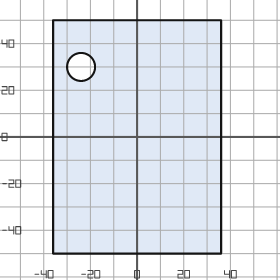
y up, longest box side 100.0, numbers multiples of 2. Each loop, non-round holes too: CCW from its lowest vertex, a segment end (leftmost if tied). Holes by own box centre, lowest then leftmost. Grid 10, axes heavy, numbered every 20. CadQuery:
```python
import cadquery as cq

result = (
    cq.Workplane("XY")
    .moveTo(-36.0, -50.0)
    .lineTo(36.0, -50.0)
    .lineTo(36.0, 50.0)
    .lineTo(-36.0, 50.0)
    .close()
    .moveTo(-24.0, 30.0)
    .circle(6.0)
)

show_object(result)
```